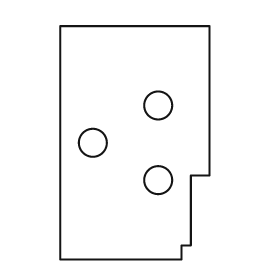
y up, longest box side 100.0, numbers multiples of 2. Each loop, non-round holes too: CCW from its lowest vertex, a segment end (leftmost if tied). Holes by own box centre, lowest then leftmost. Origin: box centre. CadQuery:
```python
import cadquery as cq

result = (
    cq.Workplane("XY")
    .moveTo(-32.0, -50.0)
    .lineTo(20.0, -50.0)
    .lineTo(20.0, -44.0)
    .lineTo(24.0, -44.0)
    .lineTo(24.0, -14.0)
    .lineTo(32.0, -14.0)
    .lineTo(32.0, 50.0)
    .lineTo(-32.0, 50.0)
    .close()
    .moveTo(10.0, -16.0)
    .circle(6.0)
    .moveTo(-18.0, 0.0)
    .circle(6.0)
    .moveTo(10.0, 16.0)
    .circle(6.0)
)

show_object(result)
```